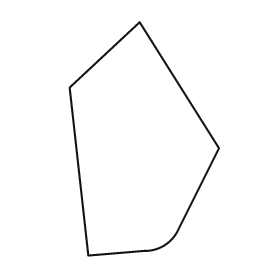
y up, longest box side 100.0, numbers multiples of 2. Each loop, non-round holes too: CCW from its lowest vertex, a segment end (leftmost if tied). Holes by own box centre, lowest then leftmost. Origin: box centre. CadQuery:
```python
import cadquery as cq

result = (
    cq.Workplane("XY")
    .moveTo(-24.0, -50.0)
    .lineTo(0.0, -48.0)
    .threePointArc((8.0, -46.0), (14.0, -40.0))
    .lineTo(32.0, -4.0)
    .lineTo(-2.0, 50.0)
    .lineTo(-32.0, 22.0)
    .close()
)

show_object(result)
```